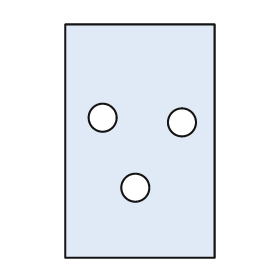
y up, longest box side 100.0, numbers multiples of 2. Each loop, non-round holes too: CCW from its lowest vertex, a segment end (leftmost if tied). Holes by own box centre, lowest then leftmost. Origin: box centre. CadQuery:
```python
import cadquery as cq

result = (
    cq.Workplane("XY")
    .moveTo(-32.0, -50.0)
    .lineTo(32.0, -50.0)
    .lineTo(32.0, 50.0)
    .lineTo(-32.0, 50.0)
    .close()
    .moveTo(-2.0, -20.0)
    .circle(6.0)
    .moveTo(18.0, 8.0)
    .circle(6.0)
    .moveTo(-16.0, 10.0)
    .circle(6.0)
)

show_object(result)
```